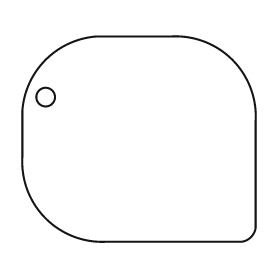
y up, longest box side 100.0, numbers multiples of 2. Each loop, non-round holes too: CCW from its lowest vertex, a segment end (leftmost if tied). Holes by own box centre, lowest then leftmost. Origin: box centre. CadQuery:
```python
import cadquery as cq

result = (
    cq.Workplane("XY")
    .moveTo(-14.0, -44.0)
    .lineTo(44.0, -44.0)
    .threePointArc((48.0, -42.0), (50.0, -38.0))
    .lineTo(50.0, 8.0)
    .threePointArc((40.0, 34.0), (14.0, 44.0))
    .lineTo(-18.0, 44.0)
    .threePointArc((-40.0, 34.0), (-50.0, 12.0))
    .lineTo(-50.0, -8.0)
    .threePointArc((-40.0, -34.0), (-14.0, -44.0))
    .close()
    .moveTo(-40.0, 18.0)
    .circle(4.0)
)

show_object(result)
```